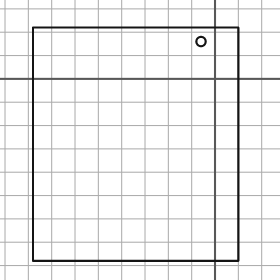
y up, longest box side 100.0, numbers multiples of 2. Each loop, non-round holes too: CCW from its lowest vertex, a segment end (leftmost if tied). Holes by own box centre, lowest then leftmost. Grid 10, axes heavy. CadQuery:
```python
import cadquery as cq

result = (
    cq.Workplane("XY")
    .moveTo(-78.0, -78.0)
    .lineTo(10.0, -78.0)
    .lineTo(10.0, 22.0)
    .lineTo(-78.0, 22.0)
    .close()
    .moveTo(-6.0, 16.0)
    .circle(2.0)
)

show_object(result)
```